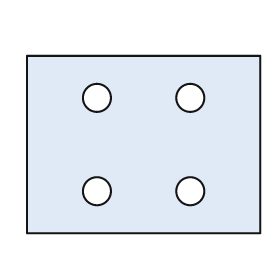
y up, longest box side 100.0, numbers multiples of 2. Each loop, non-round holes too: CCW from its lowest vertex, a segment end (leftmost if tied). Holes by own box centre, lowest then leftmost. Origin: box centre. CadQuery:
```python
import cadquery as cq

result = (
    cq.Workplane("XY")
    .moveTo(-50.0, -38.0)
    .lineTo(50.0, -38.0)
    .lineTo(50.0, 38.0)
    .lineTo(-50.0, 38.0)
    .close()
    .moveTo(-20.0, -20.0)
    .circle(6.0)
    .moveTo(20.0, -20.0)
    .circle(6.0)
    .moveTo(-20.0, 20.0)
    .circle(6.0)
    .moveTo(20.0, 20.0)
    .circle(6.0)
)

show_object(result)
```